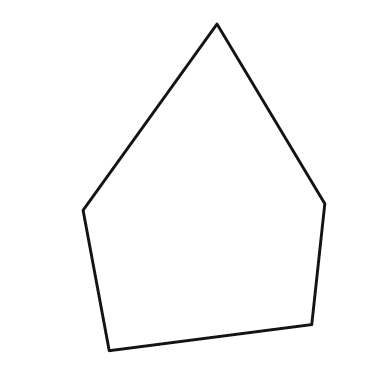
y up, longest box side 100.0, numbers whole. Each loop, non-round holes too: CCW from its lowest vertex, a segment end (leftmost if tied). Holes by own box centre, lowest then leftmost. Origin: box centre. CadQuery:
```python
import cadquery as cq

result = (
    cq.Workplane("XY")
    .moveTo(-29.0, -50.0)
    .lineTo(33.0, -42.0)
    .lineTo(37.0, -5.0)
    .lineTo(4.0, 50.0)
    .lineTo(-37.0, -7.0)
    .close()
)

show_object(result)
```